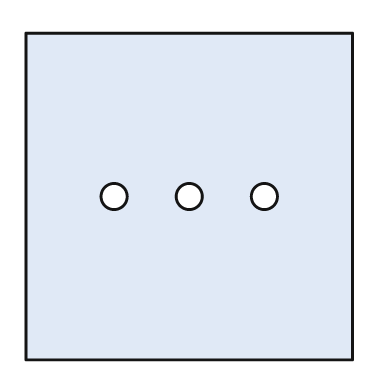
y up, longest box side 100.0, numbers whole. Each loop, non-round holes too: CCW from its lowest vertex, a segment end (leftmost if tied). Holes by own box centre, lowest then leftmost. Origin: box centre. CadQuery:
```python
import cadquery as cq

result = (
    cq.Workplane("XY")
    .moveTo(-50.0, -50.0)
    .lineTo(50.0, -50.0)
    .lineTo(50.0, 50.0)
    .lineTo(-50.0, 50.0)
    .close()
    .moveTo(-23.0, 0.0)
    .circle(4.0)
    .moveTo(0.0, 0.0)
    .circle(4.0)
    .moveTo(23.0, 0.0)
    .circle(4.0)
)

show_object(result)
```